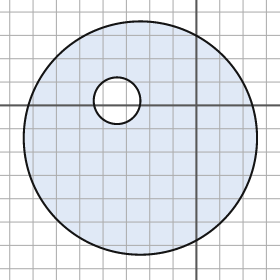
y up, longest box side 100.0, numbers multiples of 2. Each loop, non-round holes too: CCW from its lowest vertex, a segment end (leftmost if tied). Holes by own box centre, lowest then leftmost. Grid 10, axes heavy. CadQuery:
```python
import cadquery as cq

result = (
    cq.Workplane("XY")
    .moveTo(-24.0, -14.0)
    .circle(50.0)
    .moveTo(-34.0, 2.0)
    .circle(10.0)
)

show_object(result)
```